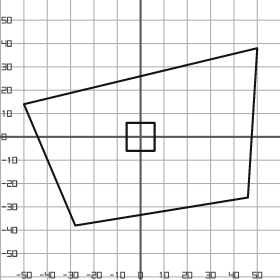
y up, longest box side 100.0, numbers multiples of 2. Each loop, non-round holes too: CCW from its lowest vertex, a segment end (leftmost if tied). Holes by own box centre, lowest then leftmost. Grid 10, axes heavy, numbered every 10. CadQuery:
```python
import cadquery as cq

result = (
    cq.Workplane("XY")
    .moveTo(-28.0, -38.0)
    .lineTo(46.0, -26.0)
    .lineTo(50.0, 38.0)
    .lineTo(-50.0, 14.0)
    .close()
    .moveTo(-6.0, -6.0)
    .lineTo(6.0, -6.0)
    .lineTo(6.0, 6.0)
    .lineTo(-6.0, 6.0)
    .close()
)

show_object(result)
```